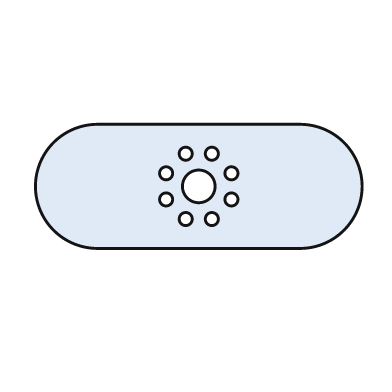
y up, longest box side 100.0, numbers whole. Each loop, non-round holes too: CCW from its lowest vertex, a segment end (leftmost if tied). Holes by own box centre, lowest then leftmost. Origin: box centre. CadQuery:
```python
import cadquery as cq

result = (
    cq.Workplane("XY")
    .moveTo(-31.0, -19.0)
    .lineTo(31.0, -19.0)
    .threePointArc((50.0, 0.0), (31.0, 19.0))
    .lineTo(-31.0, 19.0)
    .threePointArc((-50.0, 0.0), (-31.0, -19.0))
    .close()
    .moveTo(-4.0, -10.0)
    .circle(2.0)
    .moveTo(4.0, -10.0)
    .circle(2.0)
    .moveTo(-10.0, -4.0)
    .circle(2.0)
    .moveTo(10.0, -4.0)
    .circle(2.0)
    .moveTo(0.0, 0.0)
    .circle(5.0)
    .moveTo(-10.0, 4.0)
    .circle(2.0)
    .moveTo(10.0, 4.0)
    .circle(2.0)
    .moveTo(-4.0, 10.0)
    .circle(2.0)
    .moveTo(4.0, 10.0)
    .circle(2.0)
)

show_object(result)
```